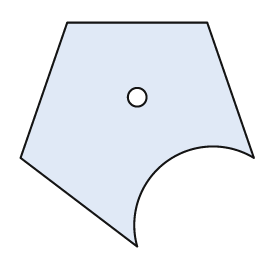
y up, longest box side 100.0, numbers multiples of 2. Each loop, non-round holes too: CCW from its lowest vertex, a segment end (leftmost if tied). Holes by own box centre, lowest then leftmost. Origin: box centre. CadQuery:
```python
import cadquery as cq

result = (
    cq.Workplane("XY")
    .moveTo(0.0, -48.0)
    .threePointArc((12.0, -12.0), (50.0, -10.0))
    .lineTo(30.0, 48.0)
    .lineTo(-30.0, 48.0)
    .lineTo(-50.0, -10.0)
    .close()
    .moveTo(0.0, 16.0)
    .circle(4.0)
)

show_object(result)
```